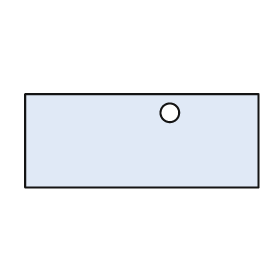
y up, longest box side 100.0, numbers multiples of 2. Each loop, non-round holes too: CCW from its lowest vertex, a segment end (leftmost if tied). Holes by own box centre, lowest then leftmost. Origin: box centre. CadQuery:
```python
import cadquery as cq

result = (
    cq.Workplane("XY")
    .moveTo(-50.0, -20.0)
    .lineTo(50.0, -20.0)
    .lineTo(50.0, 20.0)
    .lineTo(-50.0, 20.0)
    .close()
    .moveTo(12.0, 12.0)
    .circle(4.0)
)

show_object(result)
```